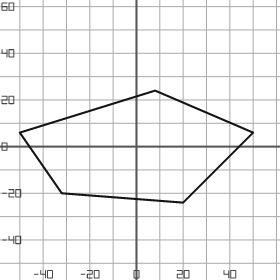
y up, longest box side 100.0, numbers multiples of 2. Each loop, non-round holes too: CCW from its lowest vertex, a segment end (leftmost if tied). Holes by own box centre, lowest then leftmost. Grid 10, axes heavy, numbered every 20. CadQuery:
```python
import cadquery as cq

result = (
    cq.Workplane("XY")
    .moveTo(20.0, -24.0)
    .lineTo(50.0, 6.0)
    .lineTo(8.0, 24.0)
    .lineTo(-50.0, 6.0)
    .lineTo(-32.0, -20.0)
    .close()
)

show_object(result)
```